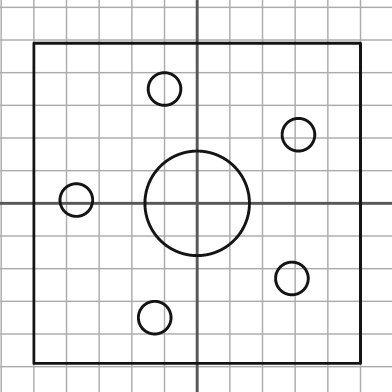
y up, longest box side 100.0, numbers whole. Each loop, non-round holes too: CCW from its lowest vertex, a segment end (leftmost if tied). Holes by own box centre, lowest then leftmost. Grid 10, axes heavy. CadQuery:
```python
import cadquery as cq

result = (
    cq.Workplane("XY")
    .moveTo(-50.0, -49.0)
    .lineTo(50.0, -49.0)
    .lineTo(50.0, 49.0)
    .lineTo(-50.0, 49.0)
    .close()
    .moveTo(-13.0, -35.0)
    .circle(5.0)
    .moveTo(29.0, -23.0)
    .circle(5.0)
    .moveTo(0.0, 0.0)
    .circle(16.0)
    .moveTo(-37.0, 1.0)
    .circle(5.0)
    .moveTo(31.0, 21.0)
    .circle(5.0)
    .moveTo(-10.0, 35.0)
    .circle(5.0)
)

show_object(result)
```